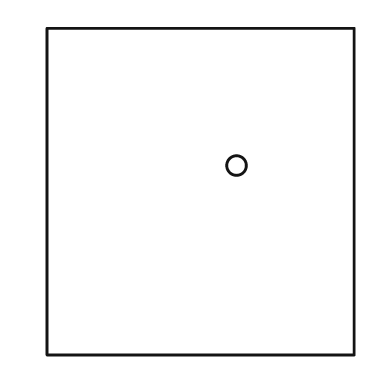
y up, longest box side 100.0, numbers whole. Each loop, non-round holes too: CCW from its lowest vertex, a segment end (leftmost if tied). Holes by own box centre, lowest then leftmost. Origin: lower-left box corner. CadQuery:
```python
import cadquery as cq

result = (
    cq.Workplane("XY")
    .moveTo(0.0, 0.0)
    .lineTo(94.0, 0.0)
    .lineTo(94.0, 100.0)
    .lineTo(0.0, 100.0)
    .close()
    .moveTo(58.0, 58.0)
    .circle(3.0)
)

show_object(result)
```